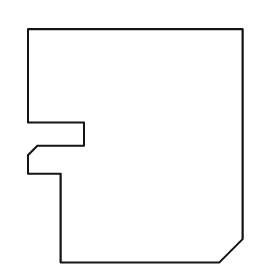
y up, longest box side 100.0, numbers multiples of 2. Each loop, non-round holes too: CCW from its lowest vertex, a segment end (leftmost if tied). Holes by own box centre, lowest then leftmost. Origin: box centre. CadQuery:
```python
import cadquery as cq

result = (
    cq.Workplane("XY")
    .moveTo(-32.0, -50.0)
    .lineTo(36.0, -50.0)
    .lineTo(46.0, -40.0)
    .lineTo(46.0, 50.0)
    .lineTo(-46.0, 50.0)
    .lineTo(-46.0, 10.0)
    .lineTo(-22.0, 10.0)
    .lineTo(-22.0, 0.0)
    .lineTo(-42.0, 0.0)
    .lineTo(-46.0, -4.0)
    .lineTo(-46.0, -12.0)
    .lineTo(-32.0, -12.0)
    .close()
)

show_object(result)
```